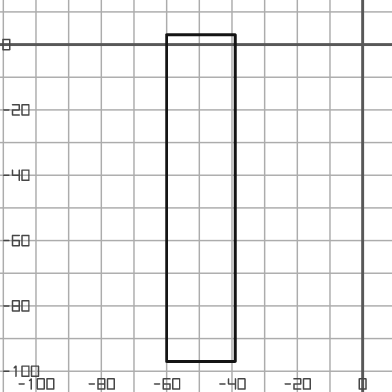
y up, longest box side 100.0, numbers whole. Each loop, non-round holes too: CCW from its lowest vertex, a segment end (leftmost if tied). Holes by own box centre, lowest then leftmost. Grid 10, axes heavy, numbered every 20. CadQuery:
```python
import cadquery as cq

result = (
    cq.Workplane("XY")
    .moveTo(-60.0, -97.0)
    .lineTo(-39.0, -97.0)
    .lineTo(-39.0, 3.0)
    .lineTo(-60.0, 3.0)
    .close()
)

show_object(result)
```